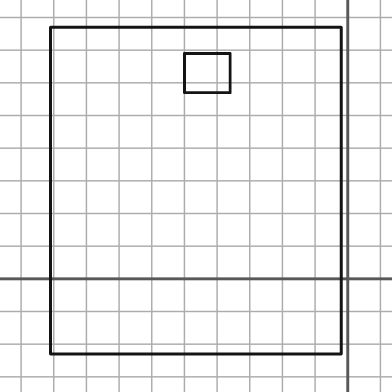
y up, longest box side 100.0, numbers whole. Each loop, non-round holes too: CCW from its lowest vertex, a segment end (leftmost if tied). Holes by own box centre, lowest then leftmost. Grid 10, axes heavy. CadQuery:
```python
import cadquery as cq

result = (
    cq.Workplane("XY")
    .moveTo(-91.0, -23.0)
    .lineTo(-2.0, -23.0)
    .lineTo(-2.0, 77.0)
    .lineTo(-91.0, 77.0)
    .close()
    .moveTo(-50.0, 57.0)
    .lineTo(-36.0, 57.0)
    .lineTo(-36.0, 69.0)
    .lineTo(-50.0, 69.0)
    .close()
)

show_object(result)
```